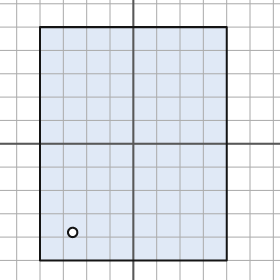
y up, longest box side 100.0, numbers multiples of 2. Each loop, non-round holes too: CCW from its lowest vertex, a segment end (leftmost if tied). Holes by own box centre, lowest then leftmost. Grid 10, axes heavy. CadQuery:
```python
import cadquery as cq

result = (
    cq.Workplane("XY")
    .moveTo(-40.0, -50.0)
    .lineTo(40.0, -50.0)
    .lineTo(40.0, 50.0)
    .lineTo(-40.0, 50.0)
    .close()
    .moveTo(-26.0, -38.0)
    .circle(2.0)
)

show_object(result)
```